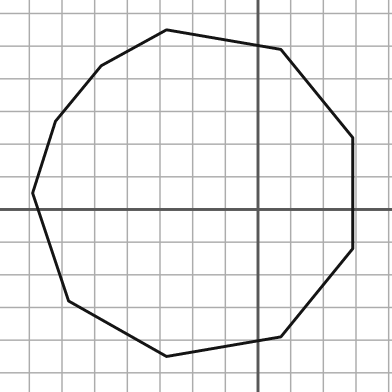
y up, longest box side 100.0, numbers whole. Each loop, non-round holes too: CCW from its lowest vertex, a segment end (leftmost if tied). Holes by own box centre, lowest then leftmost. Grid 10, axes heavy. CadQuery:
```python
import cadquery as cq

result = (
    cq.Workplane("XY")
    .moveTo(-28.0, -45.0)
    .lineTo(7.0, -39.0)
    .lineTo(29.0, -12.0)
    .lineTo(29.0, 22.0)
    .lineTo(7.0, 49.0)
    .lineTo(-28.0, 55.0)
    .lineTo(-48.0, 44.0)
    .lineTo(-62.0, 27.0)
    .lineTo(-69.0, 5.0)
    .lineTo(-58.0, -28.0)
    .close()
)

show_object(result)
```